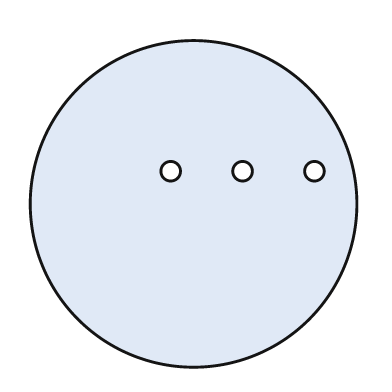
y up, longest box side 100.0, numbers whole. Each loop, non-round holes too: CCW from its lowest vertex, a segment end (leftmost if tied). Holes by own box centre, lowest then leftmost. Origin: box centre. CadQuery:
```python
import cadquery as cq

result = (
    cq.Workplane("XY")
    .moveTo(0.0, 0.0)
    .circle(50.0)
    .moveTo(-7.0, 10.0)
    .circle(3.0)
    .moveTo(15.0, 10.0)
    .circle(3.0)
    .moveTo(37.0, 10.0)
    .circle(3.0)
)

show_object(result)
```